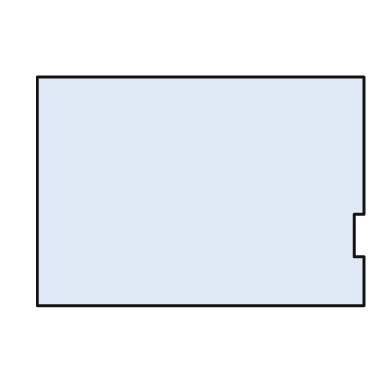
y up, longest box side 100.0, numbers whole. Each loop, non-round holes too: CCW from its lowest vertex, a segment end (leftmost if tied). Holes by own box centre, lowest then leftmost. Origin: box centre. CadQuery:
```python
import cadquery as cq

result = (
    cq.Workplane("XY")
    .moveTo(-50.0, -35.0)
    .lineTo(50.0, -35.0)
    .lineTo(50.0, -20.0)
    .lineTo(47.0, -20.0)
    .lineTo(47.0, -7.0)
    .lineTo(50.0, -7.0)
    .lineTo(50.0, 35.0)
    .lineTo(-50.0, 35.0)
    .close()
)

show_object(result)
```